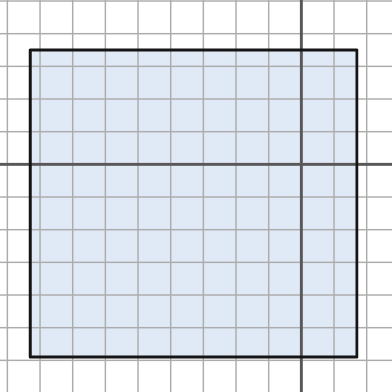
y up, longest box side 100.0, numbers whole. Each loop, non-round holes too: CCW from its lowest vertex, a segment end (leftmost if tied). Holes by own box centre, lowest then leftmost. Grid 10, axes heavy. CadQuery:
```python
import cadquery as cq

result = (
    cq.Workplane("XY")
    .moveTo(-83.0, -59.0)
    .lineTo(17.0, -59.0)
    .lineTo(17.0, 35.0)
    .lineTo(-83.0, 35.0)
    .close()
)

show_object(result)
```